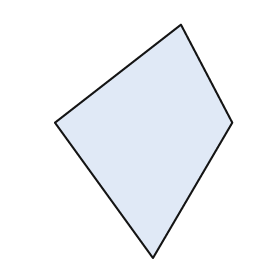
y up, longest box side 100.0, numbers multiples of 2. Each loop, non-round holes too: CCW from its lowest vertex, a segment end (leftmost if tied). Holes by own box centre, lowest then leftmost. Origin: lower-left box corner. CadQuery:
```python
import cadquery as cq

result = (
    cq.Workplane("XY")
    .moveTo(42.0, 0.0)
    .lineTo(76.0, 58.0)
    .lineTo(54.0, 100.0)
    .lineTo(0.0, 58.0)
    .close()
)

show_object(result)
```